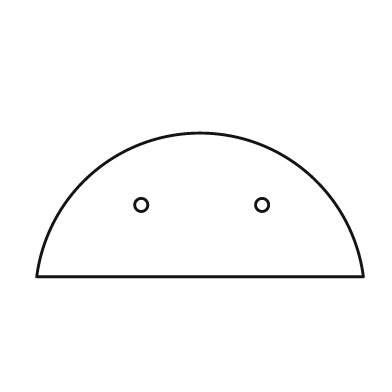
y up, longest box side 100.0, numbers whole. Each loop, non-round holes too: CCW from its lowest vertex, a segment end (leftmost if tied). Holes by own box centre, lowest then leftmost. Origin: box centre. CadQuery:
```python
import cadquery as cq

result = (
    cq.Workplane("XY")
    .moveTo(-50.0, -22.0)
    .lineTo(50.0, -22.0)
    .threePointArc((0.0, 22.0), (-50.0, -22.0))
    .close()
    .moveTo(-18.0, 0.0)
    .circle(2.0)
    .moveTo(19.0, 0.0)
    .circle(2.0)
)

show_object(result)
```